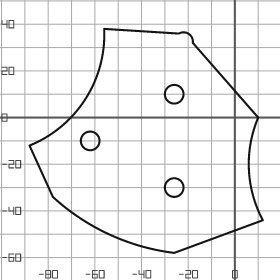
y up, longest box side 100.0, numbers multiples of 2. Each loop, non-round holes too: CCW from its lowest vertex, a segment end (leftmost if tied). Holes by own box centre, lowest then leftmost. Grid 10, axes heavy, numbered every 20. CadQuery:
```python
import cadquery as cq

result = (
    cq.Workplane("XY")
    .moveTo(-26.0, -58.0)
    .lineTo(12.0, -44.0)
    .threePointArc((6.0, -22.0), (10.0, 0.0))
    .lineTo(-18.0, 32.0)
    .threePointArc((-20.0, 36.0), (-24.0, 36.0))
    .lineTo(-56.0, 38.0)
    .threePointArc((-64.0, 8.0), (-88.0, -12.0))
    .lineTo(-78.0, -34.0)
    .threePointArc((-54.0, -50.0), (-26.0, -58.0))
    .close()
    .moveTo(-26.0, -30.0)
    .circle(4.0)
    .moveTo(-62.0, -10.0)
    .circle(4.0)
    .moveTo(-26.0, 10.0)
    .circle(4.0)
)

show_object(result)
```